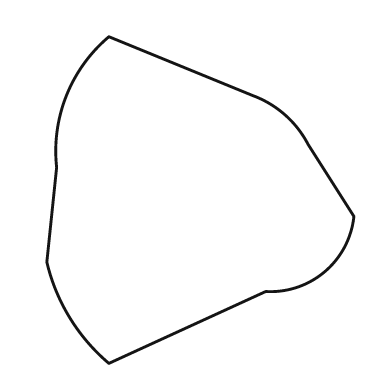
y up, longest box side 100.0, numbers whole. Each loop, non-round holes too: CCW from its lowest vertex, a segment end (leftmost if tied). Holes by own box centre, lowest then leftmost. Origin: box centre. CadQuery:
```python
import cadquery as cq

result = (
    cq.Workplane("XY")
    .moveTo(-28.0, -50.0)
    .lineTo(20.0, -28.0)
    .threePointArc((38.0, -22.0), (47.0, -5.0))
    .lineTo(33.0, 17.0)
    .threePointArc((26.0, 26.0), (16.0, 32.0))
    .lineTo(-28.0, 50.0)
    .threePointArc((-41.0, 32.0), (-44.0, 10.0))
    .lineTo(-47.0, -19.0)
    .threePointArc((-40.0, -36.0), (-28.0, -50.0))
    .close()
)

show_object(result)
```